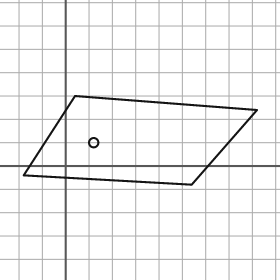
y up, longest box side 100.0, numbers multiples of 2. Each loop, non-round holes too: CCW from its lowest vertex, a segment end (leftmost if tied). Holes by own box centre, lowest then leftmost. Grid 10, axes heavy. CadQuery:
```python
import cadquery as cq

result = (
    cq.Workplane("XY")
    .moveTo(54.0, -8.0)
    .lineTo(82.0, 24.0)
    .lineTo(4.0, 30.0)
    .lineTo(-18.0, -4.0)
    .close()
    .moveTo(12.0, 10.0)
    .circle(2.0)
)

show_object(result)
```